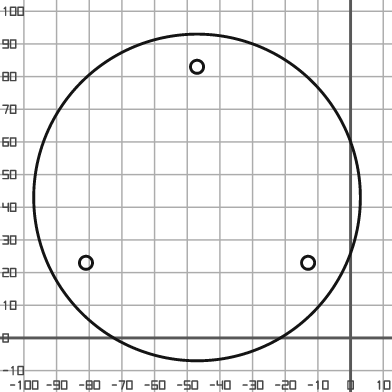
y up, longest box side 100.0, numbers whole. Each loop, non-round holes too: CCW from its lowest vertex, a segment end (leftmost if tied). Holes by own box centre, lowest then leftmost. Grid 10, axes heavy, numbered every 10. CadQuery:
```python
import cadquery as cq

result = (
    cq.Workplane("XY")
    .moveTo(-47.0, 43.0)
    .circle(50.0)
    .moveTo(-81.0, 23.0)
    .circle(2.0)
    .moveTo(-13.0, 23.0)
    .circle(2.0)
    .moveTo(-47.0, 83.0)
    .circle(2.0)
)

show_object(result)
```